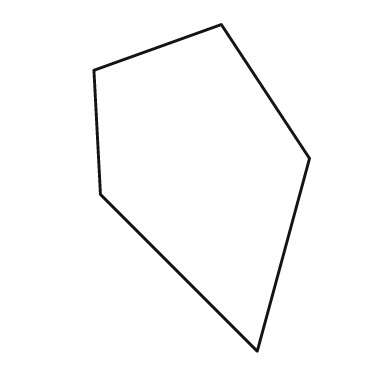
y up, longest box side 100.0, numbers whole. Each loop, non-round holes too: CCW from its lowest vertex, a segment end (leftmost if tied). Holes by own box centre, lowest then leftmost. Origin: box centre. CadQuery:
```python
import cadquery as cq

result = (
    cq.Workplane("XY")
    .moveTo(17.0, -50.0)
    .lineTo(33.0, 9.0)
    .lineTo(6.0, 50.0)
    .lineTo(-33.0, 36.0)
    .lineTo(-31.0, -2.0)
    .close()
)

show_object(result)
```